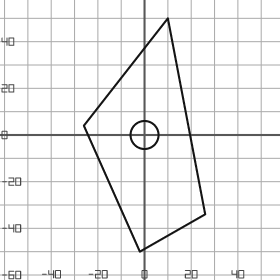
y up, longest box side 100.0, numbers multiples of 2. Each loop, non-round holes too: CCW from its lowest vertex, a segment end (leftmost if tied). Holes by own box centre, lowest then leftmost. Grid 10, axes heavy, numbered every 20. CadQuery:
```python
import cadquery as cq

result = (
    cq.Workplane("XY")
    .moveTo(-2.0, -50.0)
    .lineTo(26.0, -34.0)
    .lineTo(10.0, 50.0)
    .lineTo(-26.0, 4.0)
    .close()
    .moveTo(0.0, 0.0)
    .circle(6.0)
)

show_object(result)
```